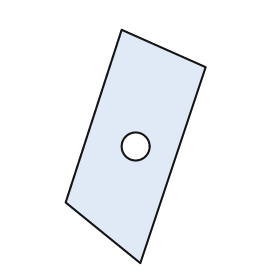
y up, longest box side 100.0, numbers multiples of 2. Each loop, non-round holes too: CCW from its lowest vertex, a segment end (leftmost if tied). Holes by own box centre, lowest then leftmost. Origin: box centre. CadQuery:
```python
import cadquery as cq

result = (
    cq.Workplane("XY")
    .moveTo(2.0, -50.0)
    .lineTo(30.0, 34.0)
    .lineTo(-6.0, 50.0)
    .lineTo(-30.0, -24.0)
    .close()
    .moveTo(0.0, 0.0)
    .circle(6.0)
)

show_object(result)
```